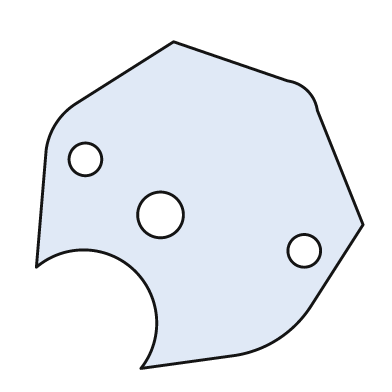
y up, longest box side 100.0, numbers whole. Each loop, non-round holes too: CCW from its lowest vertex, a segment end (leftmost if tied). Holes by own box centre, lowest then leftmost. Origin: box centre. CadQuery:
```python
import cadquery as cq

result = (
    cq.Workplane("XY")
    .moveTo(-18.0, -50.0)
    .lineTo(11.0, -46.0)
    .threePointArc((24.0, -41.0), (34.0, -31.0))
    .lineTo(50.0, -6.0)
    .lineTo(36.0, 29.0)
    .threePointArc((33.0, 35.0), (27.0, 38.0))
    .lineTo(-8.0, 50.0)
    .lineTo(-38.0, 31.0)
    .threePointArc((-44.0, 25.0), (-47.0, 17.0))
    .lineTo(-50.0, -19.0)
    .threePointArc((-20.0, -20.0), (-18.0, -50.0))
    .close()
    .moveTo(32.0, -14.0)
    .circle(5.0)
    .moveTo(-12.0, -3.0)
    .circle(7.0)
    .moveTo(-35.0, 14.0)
    .circle(5.0)
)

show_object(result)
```